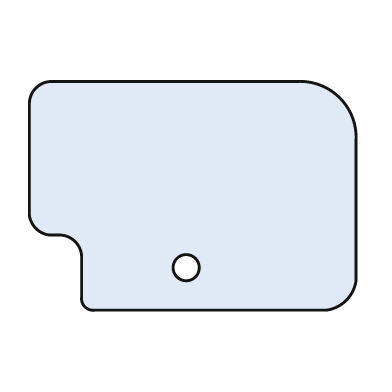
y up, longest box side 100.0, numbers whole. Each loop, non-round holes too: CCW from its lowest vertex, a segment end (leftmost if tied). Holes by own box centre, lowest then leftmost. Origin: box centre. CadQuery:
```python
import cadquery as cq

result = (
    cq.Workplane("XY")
    .moveTo(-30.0, -35.0)
    .lineTo(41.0, -35.0)
    .threePointArc((47.0, -32.0), (50.0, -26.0))
    .lineTo(50.0, 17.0)
    .threePointArc((45.0, 30.0), (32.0, 35.0))
    .lineTo(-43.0, 35.0)
    .threePointArc((-48.0, 33.0), (-50.0, 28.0))
    .lineTo(-50.0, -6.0)
    .threePointArc((-48.0, -10.0), (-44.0, -12.0))
    .lineTo(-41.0, -12.0)
    .threePointArc((-36.0, -14.0), (-34.0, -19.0))
    .lineTo(-34.0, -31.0)
    .threePointArc((-33.0, -34.0), (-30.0, -35.0))
    .close()
    .moveTo(-2.0, -22.0)
    .circle(4.0)
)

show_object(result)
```